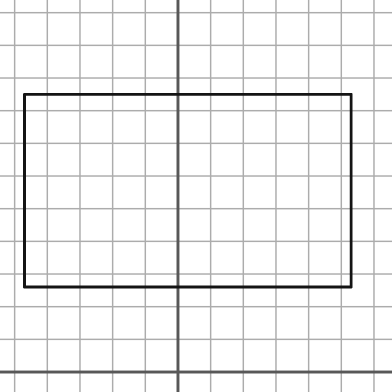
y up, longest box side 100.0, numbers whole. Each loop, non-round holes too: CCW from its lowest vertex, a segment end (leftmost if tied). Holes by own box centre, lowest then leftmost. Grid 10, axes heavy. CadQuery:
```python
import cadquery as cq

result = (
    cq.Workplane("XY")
    .moveTo(-47.0, 26.0)
    .lineTo(53.0, 26.0)
    .lineTo(53.0, 85.0)
    .lineTo(-47.0, 85.0)
    .close()
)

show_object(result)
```